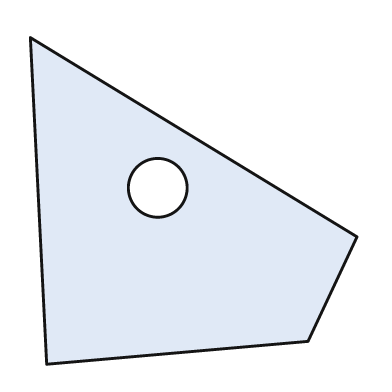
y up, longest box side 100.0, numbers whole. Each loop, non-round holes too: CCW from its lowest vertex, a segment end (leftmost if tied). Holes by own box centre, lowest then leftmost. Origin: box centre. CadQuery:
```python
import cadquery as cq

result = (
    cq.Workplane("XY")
    .moveTo(-45.0, -50.0)
    .lineTo(35.0, -43.0)
    .lineTo(50.0, -11.0)
    .lineTo(-50.0, 50.0)
    .close()
    .moveTo(-11.0, 4.0)
    .circle(9.0)
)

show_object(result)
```